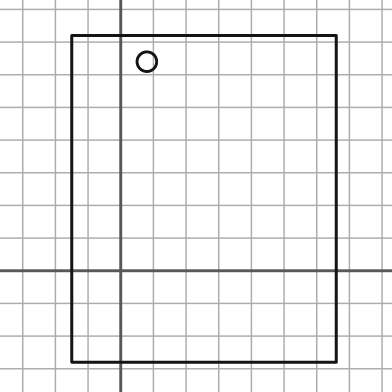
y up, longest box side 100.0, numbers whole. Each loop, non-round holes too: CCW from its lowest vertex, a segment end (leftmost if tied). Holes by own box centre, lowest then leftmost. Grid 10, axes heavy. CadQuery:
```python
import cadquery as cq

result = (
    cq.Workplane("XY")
    .moveTo(-15.0, -28.0)
    .lineTo(66.0, -28.0)
    .lineTo(66.0, 72.0)
    .lineTo(-15.0, 72.0)
    .close()
    .moveTo(8.0, 64.0)
    .circle(3.0)
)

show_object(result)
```